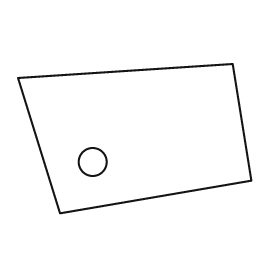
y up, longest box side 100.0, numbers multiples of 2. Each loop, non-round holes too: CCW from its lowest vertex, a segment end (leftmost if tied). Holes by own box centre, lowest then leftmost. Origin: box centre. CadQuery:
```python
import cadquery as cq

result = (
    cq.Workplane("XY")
    .moveTo(-32.0, -32.0)
    .lineTo(50.0, -18.0)
    .lineTo(42.0, 32.0)
    .lineTo(-50.0, 26.0)
    .close()
    .moveTo(-18.0, -10.0)
    .circle(6.0)
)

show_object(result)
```